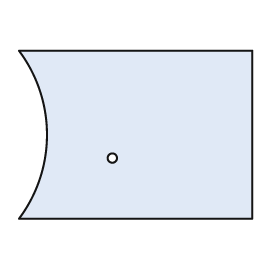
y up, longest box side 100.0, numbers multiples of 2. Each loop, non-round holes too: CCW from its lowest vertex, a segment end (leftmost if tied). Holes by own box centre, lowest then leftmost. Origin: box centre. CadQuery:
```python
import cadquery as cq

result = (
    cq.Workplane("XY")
    .moveTo(-50.0, -36.0)
    .lineTo(50.0, -36.0)
    .lineTo(50.0, 36.0)
    .lineTo(-50.0, 36.0)
    .threePointArc((-38.0, 0.0), (-50.0, -36.0))
    .close()
    .moveTo(-10.0, -10.0)
    .circle(2.0)
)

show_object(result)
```